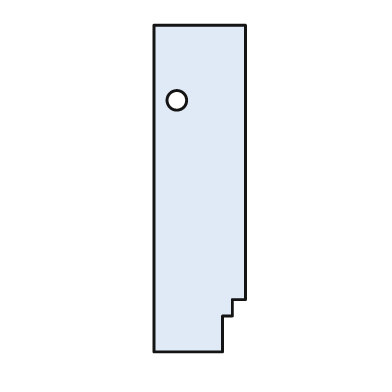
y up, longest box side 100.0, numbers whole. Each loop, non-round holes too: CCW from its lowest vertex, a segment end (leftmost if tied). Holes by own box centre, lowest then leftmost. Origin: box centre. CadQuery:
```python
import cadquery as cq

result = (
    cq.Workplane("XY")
    .moveTo(-14.0, -50.0)
    .lineTo(7.0, -50.0)
    .lineTo(7.0, -39.0)
    .lineTo(10.0, -39.0)
    .lineTo(10.0, -34.0)
    .lineTo(14.0, -34.0)
    .lineTo(14.0, 50.0)
    .lineTo(-14.0, 50.0)
    .close()
    .moveTo(-7.0, 27.0)
    .circle(3.0)
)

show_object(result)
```